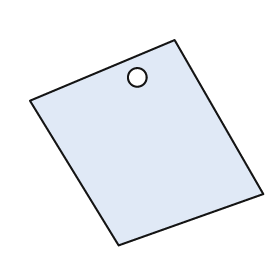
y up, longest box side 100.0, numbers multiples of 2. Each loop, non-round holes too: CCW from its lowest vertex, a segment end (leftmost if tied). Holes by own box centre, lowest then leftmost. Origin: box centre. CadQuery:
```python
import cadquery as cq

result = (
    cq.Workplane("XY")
    .moveTo(-12.0, -44.0)
    .lineTo(50.0, -22.0)
    .lineTo(12.0, 44.0)
    .lineTo(-50.0, 18.0)
    .close()
    .moveTo(-4.0, 28.0)
    .circle(4.0)
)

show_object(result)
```